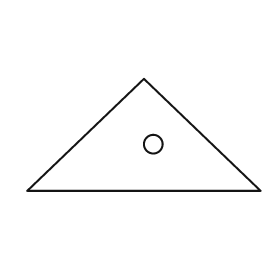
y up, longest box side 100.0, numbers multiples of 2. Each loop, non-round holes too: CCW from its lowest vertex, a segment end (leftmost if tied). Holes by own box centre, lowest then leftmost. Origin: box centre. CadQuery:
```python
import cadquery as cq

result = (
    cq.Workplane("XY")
    .moveTo(-50.0, -24.0)
    .lineTo(50.0, -24.0)
    .lineTo(0.0, 24.0)
    .close()
    .moveTo(4.0, -4.0)
    .circle(4.0)
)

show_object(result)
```